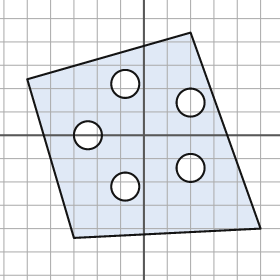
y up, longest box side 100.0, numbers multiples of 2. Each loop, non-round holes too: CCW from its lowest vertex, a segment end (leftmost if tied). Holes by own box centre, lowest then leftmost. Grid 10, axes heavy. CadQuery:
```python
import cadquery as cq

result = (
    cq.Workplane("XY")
    .moveTo(-30.0, -44.0)
    .lineTo(50.0, -40.0)
    .lineTo(20.0, 44.0)
    .lineTo(-50.0, 24.0)
    .close()
    .moveTo(-8.0, -22.0)
    .circle(6.0)
    .moveTo(20.0, -14.0)
    .circle(6.0)
    .moveTo(-24.0, 0.0)
    .circle(6.0)
    .moveTo(20.0, 14.0)
    .circle(6.0)
    .moveTo(-8.0, 22.0)
    .circle(6.0)
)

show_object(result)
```